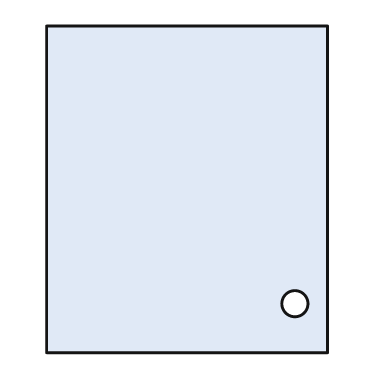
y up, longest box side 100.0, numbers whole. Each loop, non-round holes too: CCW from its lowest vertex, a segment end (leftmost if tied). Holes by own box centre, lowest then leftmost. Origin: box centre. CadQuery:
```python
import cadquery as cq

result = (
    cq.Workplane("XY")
    .moveTo(-43.0, -50.0)
    .lineTo(43.0, -50.0)
    .lineTo(43.0, 50.0)
    .lineTo(-43.0, 50.0)
    .close()
    .moveTo(33.0, -35.0)
    .circle(4.0)
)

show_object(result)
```